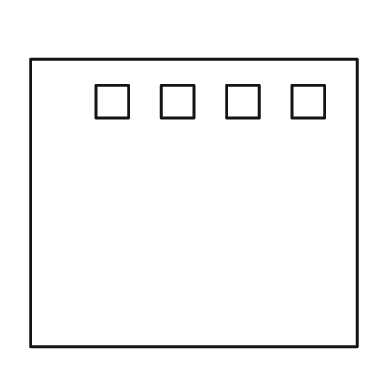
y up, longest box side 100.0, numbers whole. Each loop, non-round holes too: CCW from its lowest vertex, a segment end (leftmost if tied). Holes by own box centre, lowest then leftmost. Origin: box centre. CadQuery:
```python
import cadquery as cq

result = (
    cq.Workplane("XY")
    .moveTo(-50.0, -44.0)
    .lineTo(50.0, -44.0)
    .lineTo(50.0, 44.0)
    .lineTo(-50.0, 44.0)
    .close()
    .moveTo(-30.0, 26.0)
    .lineTo(-20.0, 26.0)
    .lineTo(-20.0, 36.0)
    .lineTo(-30.0, 36.0)
    .close()
    .moveTo(-10.0, 26.0)
    .lineTo(0.0, 26.0)
    .lineTo(0.0, 36.0)
    .lineTo(-10.0, 36.0)
    .close()
    .moveTo(10.0, 26.0)
    .lineTo(20.0, 26.0)
    .lineTo(20.0, 36.0)
    .lineTo(10.0, 36.0)
    .close()
    .moveTo(30.0, 26.0)
    .lineTo(40.0, 26.0)
    .lineTo(40.0, 36.0)
    .lineTo(30.0, 36.0)
    .close()
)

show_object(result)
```